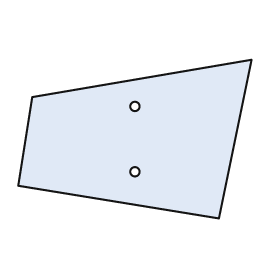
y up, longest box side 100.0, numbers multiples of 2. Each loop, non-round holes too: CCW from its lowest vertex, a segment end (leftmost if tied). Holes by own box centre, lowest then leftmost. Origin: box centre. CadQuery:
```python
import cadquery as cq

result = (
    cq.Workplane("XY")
    .moveTo(36.0, -34.0)
    .lineTo(50.0, 34.0)
    .lineTo(-44.0, 18.0)
    .lineTo(-50.0, -20.0)
    .close()
    .moveTo(0.0, -14.0)
    .circle(2.0)
    .moveTo(0.0, 14.0)
    .circle(2.0)
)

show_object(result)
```